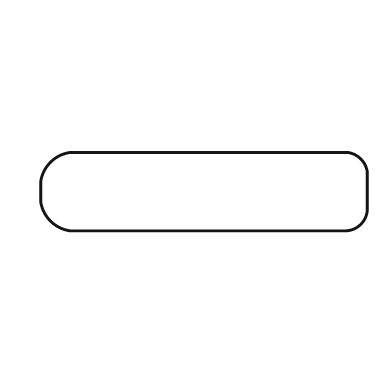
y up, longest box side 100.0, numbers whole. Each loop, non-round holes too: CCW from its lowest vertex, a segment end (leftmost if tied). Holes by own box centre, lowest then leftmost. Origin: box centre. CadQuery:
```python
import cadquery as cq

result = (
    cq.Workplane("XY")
    .moveTo(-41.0, -12.0)
    .lineTo(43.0, -12.0)
    .threePointArc((48.0, -10.0), (50.0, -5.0))
    .lineTo(50.0, 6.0)
    .threePointArc((48.0, 10.0), (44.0, 12.0))
    .lineTo(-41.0, 12.0)
    .threePointArc((-47.0, 9.0), (-50.0, 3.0))
    .lineTo(-50.0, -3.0)
    .threePointArc((-47.0, -9.0), (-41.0, -12.0))
    .close()
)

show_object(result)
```